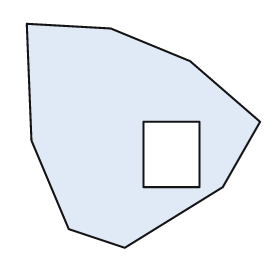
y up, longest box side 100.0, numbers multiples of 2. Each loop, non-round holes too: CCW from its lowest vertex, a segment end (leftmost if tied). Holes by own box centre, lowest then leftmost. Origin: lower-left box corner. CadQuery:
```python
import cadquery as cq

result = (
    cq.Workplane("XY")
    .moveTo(42.0, 0.0)
    .lineTo(84.0, 26.0)
    .lineTo(100.0, 54.0)
    .lineTo(70.0, 80.0)
    .lineTo(36.0, 94.0)
    .lineTo(0.0, 96.0)
    .lineTo(2.0, 46.0)
    .lineTo(18.0, 8.0)
    .close()
    .moveTo(50.0, 26.0)
    .lineTo(74.0, 26.0)
    .lineTo(74.0, 54.0)
    .lineTo(50.0, 54.0)
    .close()
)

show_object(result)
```